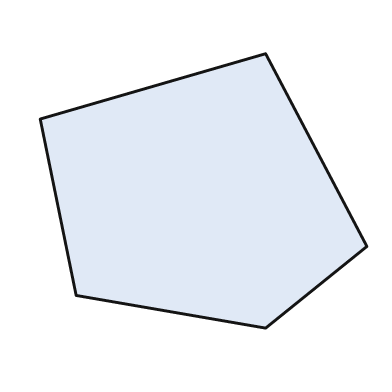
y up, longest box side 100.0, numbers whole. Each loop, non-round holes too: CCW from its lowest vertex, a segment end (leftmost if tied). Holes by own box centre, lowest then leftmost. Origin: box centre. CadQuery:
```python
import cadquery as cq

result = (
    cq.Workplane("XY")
    .moveTo(19.0, -42.0)
    .lineTo(50.0, -17.0)
    .lineTo(19.0, 42.0)
    .lineTo(-50.0, 22.0)
    .lineTo(-39.0, -32.0)
    .close()
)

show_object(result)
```